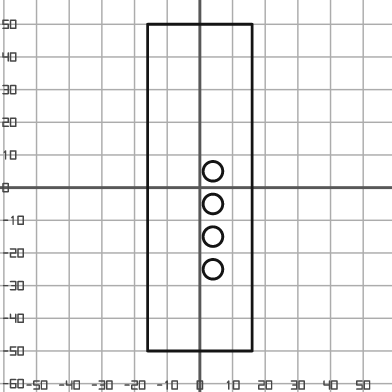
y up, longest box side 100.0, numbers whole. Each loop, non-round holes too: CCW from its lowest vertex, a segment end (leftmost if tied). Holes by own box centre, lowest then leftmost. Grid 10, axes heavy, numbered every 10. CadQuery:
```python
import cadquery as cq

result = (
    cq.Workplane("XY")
    .moveTo(-16.0, -50.0)
    .lineTo(16.0, -50.0)
    .lineTo(16.0, 50.0)
    .lineTo(-16.0, 50.0)
    .close()
    .moveTo(4.0, -25.0)
    .circle(3.0)
    .moveTo(4.0, -15.0)
    .circle(3.0)
    .moveTo(4.0, -5.0)
    .circle(3.0)
    .moveTo(4.0, 5.0)
    .circle(3.0)
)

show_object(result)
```